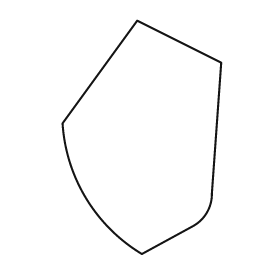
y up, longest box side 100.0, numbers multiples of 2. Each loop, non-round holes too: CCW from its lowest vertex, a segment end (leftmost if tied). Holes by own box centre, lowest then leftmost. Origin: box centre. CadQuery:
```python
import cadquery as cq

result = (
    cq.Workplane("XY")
    .moveTo(0.0, -50.0)
    .lineTo(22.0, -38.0)
    .threePointArc((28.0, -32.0), (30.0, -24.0))
    .lineTo(34.0, 32.0)
    .lineTo(-2.0, 50.0)
    .lineTo(-34.0, 6.0)
    .threePointArc((-24.0, -26.0), (0.0, -50.0))
    .close()
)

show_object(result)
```